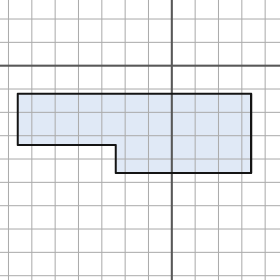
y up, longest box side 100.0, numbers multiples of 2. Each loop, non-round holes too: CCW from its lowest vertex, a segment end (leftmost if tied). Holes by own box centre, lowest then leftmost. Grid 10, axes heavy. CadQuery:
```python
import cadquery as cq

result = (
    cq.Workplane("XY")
    .moveTo(-24.0, -46.0)
    .lineTo(34.0, -46.0)
    .lineTo(34.0, -12.0)
    .lineTo(-66.0, -12.0)
    .lineTo(-66.0, -34.0)
    .lineTo(-24.0, -34.0)
    .close()
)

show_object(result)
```